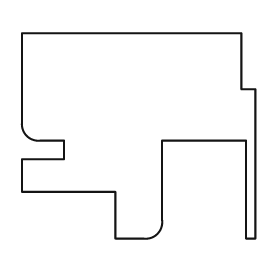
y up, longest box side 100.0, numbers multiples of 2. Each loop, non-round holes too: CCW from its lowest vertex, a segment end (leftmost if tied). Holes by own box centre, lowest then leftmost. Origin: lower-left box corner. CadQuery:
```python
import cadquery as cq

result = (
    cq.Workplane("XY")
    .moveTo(40.0, 0.0)
    .lineTo(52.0, 0.0)
    .threePointArc((58.0, 2.0), (60.0, 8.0))
    .lineTo(60.0, 42.0)
    .lineTo(96.0, 42.0)
    .lineTo(96.0, 0.0)
    .lineTo(100.0, 0.0)
    .lineTo(100.0, 64.0)
    .lineTo(94.0, 64.0)
    .lineTo(94.0, 88.0)
    .lineTo(0.0, 88.0)
    .lineTo(0.0, 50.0)
    .threePointArc((2.0, 44.0), (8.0, 42.0))
    .lineTo(18.0, 42.0)
    .lineTo(18.0, 34.0)
    .lineTo(0.0, 34.0)
    .lineTo(0.0, 20.0)
    .lineTo(40.0, 20.0)
    .close()
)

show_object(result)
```